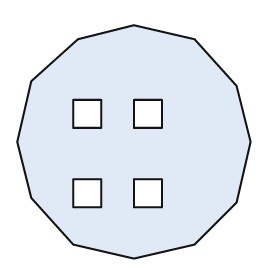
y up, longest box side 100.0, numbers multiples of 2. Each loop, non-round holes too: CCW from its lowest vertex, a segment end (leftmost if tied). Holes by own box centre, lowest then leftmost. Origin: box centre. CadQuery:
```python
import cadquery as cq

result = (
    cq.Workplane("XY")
    .moveTo(0.0, -50.0)
    .lineTo(26.0, -44.0)
    .lineTo(44.0, -26.0)
    .lineTo(50.0, 0.0)
    .lineTo(44.0, 24.0)
    .lineTo(26.0, 44.0)
    .lineTo(0.0, 50.0)
    .lineTo(-24.0, 44.0)
    .lineTo(-44.0, 26.0)
    .lineTo(-50.0, 0.0)
    .lineTo(-44.0, -24.0)
    .lineTo(-26.0, -44.0)
    .close()
    .moveTo(-26.0, -28.0)
    .lineTo(-14.0, -28.0)
    .lineTo(-14.0, -16.0)
    .lineTo(-26.0, -16.0)
    .close()
    .moveTo(0.0, -28.0)
    .lineTo(12.0, -28.0)
    .lineTo(12.0, -16.0)
    .lineTo(0.0, -16.0)
    .close()
    .moveTo(-26.0, 6.0)
    .lineTo(-14.0, 6.0)
    .lineTo(-14.0, 18.0)
    .lineTo(-26.0, 18.0)
    .close()
    .moveTo(0.0, 6.0)
    .lineTo(12.0, 6.0)
    .lineTo(12.0, 18.0)
    .lineTo(0.0, 18.0)
    .close()
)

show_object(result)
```